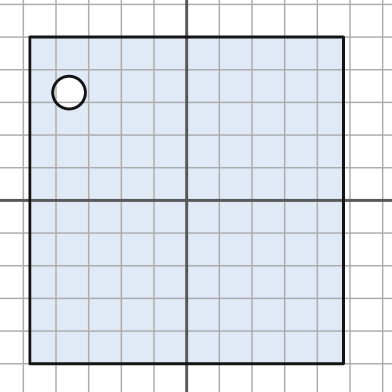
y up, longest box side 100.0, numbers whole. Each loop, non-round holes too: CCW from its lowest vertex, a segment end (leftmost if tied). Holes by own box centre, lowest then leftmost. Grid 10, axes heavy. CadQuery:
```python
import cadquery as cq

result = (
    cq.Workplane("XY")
    .moveTo(-48.0, -50.0)
    .lineTo(48.0, -50.0)
    .lineTo(48.0, 50.0)
    .lineTo(-48.0, 50.0)
    .close()
    .moveTo(-36.0, 33.0)
    .circle(5.0)
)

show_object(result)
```